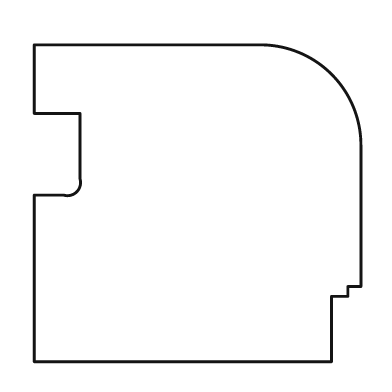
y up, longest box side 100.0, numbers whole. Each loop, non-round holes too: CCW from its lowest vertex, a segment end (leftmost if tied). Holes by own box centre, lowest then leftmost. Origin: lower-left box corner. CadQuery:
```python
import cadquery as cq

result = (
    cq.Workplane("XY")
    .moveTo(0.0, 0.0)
    .lineTo(91.0, 0.0)
    .lineTo(91.0, 20.0)
    .lineTo(96.0, 20.0)
    .lineTo(96.0, 23.0)
    .lineTo(100.0, 23.0)
    .lineTo(100.0, 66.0)
    .threePointArc((91.0, 88.0), (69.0, 97.0))
    .lineTo(0.0, 97.0)
    .lineTo(0.0, 76.0)
    .lineTo(14.0, 76.0)
    .lineTo(14.0, 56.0)
    .threePointArc((13.0, 52.0), (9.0, 51.0))
    .lineTo(0.0, 51.0)
    .close()
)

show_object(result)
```